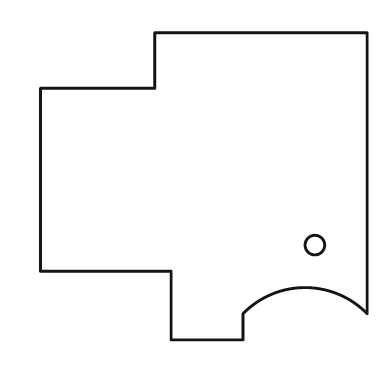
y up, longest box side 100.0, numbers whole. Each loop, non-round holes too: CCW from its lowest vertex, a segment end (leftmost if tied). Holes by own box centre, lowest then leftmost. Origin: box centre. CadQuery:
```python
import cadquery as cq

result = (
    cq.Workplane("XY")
    .moveTo(-10.0, -47.0)
    .lineTo(12.0, -47.0)
    .lineTo(12.0, -39.0)
    .threePointArc((31.0, -31.0), (50.0, -39.0))
    .lineTo(50.0, 47.0)
    .lineTo(-15.0, 47.0)
    .lineTo(-15.0, 30.0)
    .lineTo(-50.0, 30.0)
    .lineTo(-50.0, -26.0)
    .lineTo(-10.0, -26.0)
    .close()
    .moveTo(34.0, -18.0)
    .circle(3.0)
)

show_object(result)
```